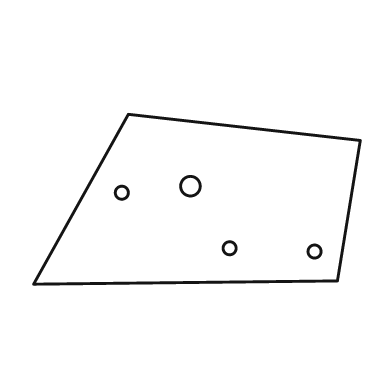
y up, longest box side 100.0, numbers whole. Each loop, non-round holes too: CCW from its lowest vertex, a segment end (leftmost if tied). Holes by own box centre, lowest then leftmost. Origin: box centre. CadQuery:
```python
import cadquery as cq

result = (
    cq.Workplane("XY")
    .moveTo(-50.0, -26.0)
    .lineTo(43.0, -25.0)
    .lineTo(50.0, 18.0)
    .lineTo(-21.0, 26.0)
    .close()
    .moveTo(36.0, -16.0)
    .circle(2.0)
    .moveTo(10.0, -15.0)
    .circle(2.0)
    .moveTo(-23.0, 2.0)
    .circle(2.0)
    .moveTo(-2.0, 4.0)
    .circle(3.0)
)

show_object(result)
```